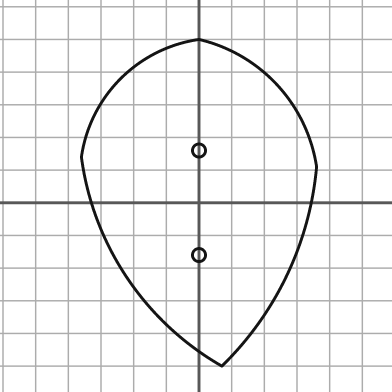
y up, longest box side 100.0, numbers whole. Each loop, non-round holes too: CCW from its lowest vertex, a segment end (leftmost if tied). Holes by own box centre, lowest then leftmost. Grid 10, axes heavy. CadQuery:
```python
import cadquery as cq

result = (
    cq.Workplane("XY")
    .moveTo(7.0, -50.0)
    .threePointArc((27.0, -22.0), (36.0, 11.0))
    .threePointArc((24.0, 36.0), (0.0, 50.0))
    .threePointArc((-24.0, 38.0), (-36.0, 14.0))
    .threePointArc((-22.0, -23.0), (7.0, -50.0))
    .close()
    .moveTo(0.0, -16.0)
    .circle(2.0)
    .moveTo(0.0, 16.0)
    .circle(2.0)
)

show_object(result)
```